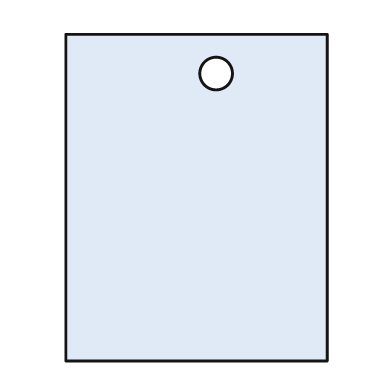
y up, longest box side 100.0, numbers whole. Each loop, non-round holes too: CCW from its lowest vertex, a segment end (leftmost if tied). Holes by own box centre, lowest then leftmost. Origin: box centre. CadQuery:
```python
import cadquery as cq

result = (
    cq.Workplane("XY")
    .moveTo(-40.0, -50.0)
    .lineTo(40.0, -50.0)
    .lineTo(40.0, 50.0)
    .lineTo(-40.0, 50.0)
    .close()
    .moveTo(6.0, 38.0)
    .circle(5.0)
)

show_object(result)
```